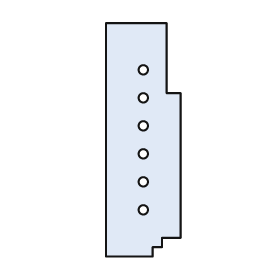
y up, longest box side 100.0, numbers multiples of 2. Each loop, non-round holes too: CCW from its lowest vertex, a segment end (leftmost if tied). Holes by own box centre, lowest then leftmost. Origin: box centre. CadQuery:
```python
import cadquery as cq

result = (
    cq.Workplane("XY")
    .moveTo(-16.0, -50.0)
    .lineTo(4.0, -50.0)
    .lineTo(4.0, -46.0)
    .lineTo(8.0, -46.0)
    .lineTo(8.0, -42.0)
    .lineTo(16.0, -42.0)
    .lineTo(16.0, 20.0)
    .lineTo(10.0, 20.0)
    .lineTo(10.0, 50.0)
    .lineTo(-16.0, 50.0)
    .close()
    .moveTo(0.0, -30.0)
    .circle(2.0)
    .moveTo(0.0, -18.0)
    .circle(2.0)
    .moveTo(0.0, -6.0)
    .circle(2.0)
    .moveTo(0.0, 6.0)
    .circle(2.0)
    .moveTo(0.0, 18.0)
    .circle(2.0)
    .moveTo(0.0, 30.0)
    .circle(2.0)
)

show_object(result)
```